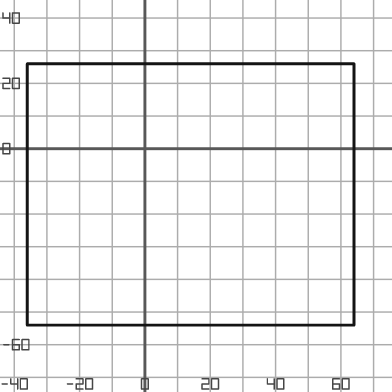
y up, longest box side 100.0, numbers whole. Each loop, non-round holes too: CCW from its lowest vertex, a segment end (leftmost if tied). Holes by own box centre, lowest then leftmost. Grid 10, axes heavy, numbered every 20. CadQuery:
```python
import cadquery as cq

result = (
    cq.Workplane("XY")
    .moveTo(-36.0, -54.0)
    .lineTo(64.0, -54.0)
    .lineTo(64.0, 26.0)
    .lineTo(-36.0, 26.0)
    .close()
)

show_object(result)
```